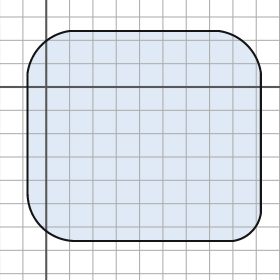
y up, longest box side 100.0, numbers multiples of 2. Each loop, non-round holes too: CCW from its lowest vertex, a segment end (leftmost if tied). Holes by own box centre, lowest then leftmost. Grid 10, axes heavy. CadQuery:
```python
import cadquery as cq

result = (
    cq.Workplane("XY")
    .moveTo(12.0, -66.0)
    .lineTo(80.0, -66.0)
    .threePointArc((88.0, -62.0), (92.0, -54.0))
    .lineTo(92.0, 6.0)
    .threePointArc((86.0, 18.0), (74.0, 24.0))
    .lineTo(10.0, 24.0)
    .threePointArc((-2.0, 18.0), (-8.0, 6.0))
    .lineTo(-8.0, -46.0)
    .threePointArc((-2.0, -60.0), (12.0, -66.0))
    .close()
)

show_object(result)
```